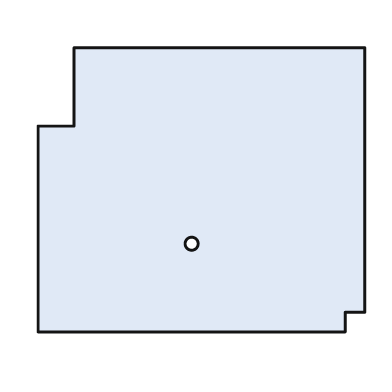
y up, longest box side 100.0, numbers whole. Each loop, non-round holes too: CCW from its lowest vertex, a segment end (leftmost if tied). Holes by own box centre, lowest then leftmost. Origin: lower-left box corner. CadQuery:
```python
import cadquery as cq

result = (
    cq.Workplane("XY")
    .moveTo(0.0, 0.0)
    .lineTo(94.0, 0.0)
    .lineTo(94.0, 6.0)
    .lineTo(100.0, 6.0)
    .lineTo(100.0, 87.0)
    .lineTo(11.0, 87.0)
    .lineTo(11.0, 63.0)
    .lineTo(0.0, 63.0)
    .close()
    .moveTo(47.0, 27.0)
    .circle(2.0)
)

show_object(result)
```